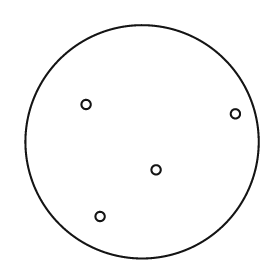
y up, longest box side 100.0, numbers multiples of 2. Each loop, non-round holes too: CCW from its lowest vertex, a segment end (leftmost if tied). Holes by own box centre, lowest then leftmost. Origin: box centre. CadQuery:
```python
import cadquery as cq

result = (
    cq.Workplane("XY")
    .moveTo(0.0, 0.0)
    .circle(50.0)
    .moveTo(-18.0, -32.0)
    .circle(2.0)
    .moveTo(6.0, -12.0)
    .circle(2.0)
    .moveTo(40.0, 12.0)
    .circle(2.0)
    .moveTo(-24.0, 16.0)
    .circle(2.0)
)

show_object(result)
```